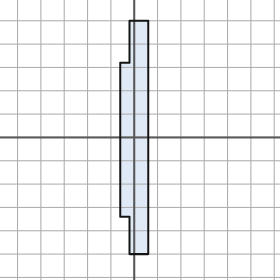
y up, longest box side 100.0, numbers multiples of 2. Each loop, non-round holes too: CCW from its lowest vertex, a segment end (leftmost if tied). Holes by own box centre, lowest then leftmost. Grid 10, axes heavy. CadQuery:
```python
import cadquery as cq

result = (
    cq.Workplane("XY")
    .moveTo(-2.0, -50.0)
    .lineTo(6.0, -50.0)
    .lineTo(6.0, 50.0)
    .lineTo(-2.0, 50.0)
    .lineTo(-2.0, 32.0)
    .lineTo(-6.0, 32.0)
    .lineTo(-6.0, -34.0)
    .lineTo(-2.0, -34.0)
    .close()
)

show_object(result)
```